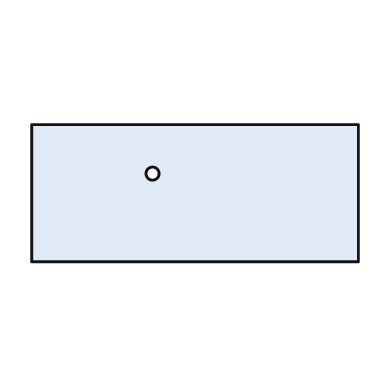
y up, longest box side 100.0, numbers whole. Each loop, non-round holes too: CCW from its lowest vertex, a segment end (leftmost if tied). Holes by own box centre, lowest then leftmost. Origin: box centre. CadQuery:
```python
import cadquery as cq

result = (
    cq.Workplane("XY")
    .moveTo(-50.0, -21.0)
    .lineTo(50.0, -21.0)
    .lineTo(50.0, 21.0)
    .lineTo(-50.0, 21.0)
    .close()
    .moveTo(-13.0, 6.0)
    .circle(2.0)
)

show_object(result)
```